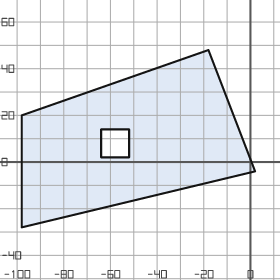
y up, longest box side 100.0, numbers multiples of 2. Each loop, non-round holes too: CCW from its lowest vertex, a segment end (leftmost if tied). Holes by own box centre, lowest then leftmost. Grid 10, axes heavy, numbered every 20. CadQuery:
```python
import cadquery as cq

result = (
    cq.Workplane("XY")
    .moveTo(-98.0, -28.0)
    .lineTo(2.0, -4.0)
    .lineTo(-18.0, 48.0)
    .lineTo(-98.0, 20.0)
    .close()
    .moveTo(-64.0, 2.0)
    .lineTo(-52.0, 2.0)
    .lineTo(-52.0, 14.0)
    .lineTo(-64.0, 14.0)
    .close()
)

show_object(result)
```